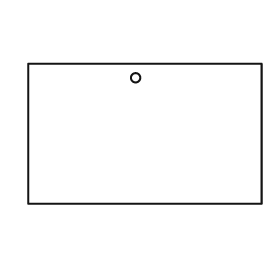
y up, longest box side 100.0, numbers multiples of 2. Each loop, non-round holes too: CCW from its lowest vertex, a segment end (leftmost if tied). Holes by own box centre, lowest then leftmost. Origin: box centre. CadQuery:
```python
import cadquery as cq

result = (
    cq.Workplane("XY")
    .moveTo(-50.0, -30.0)
    .lineTo(50.0, -30.0)
    .lineTo(50.0, 30.0)
    .lineTo(-50.0, 30.0)
    .close()
    .moveTo(-4.0, 24.0)
    .circle(2.0)
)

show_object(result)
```